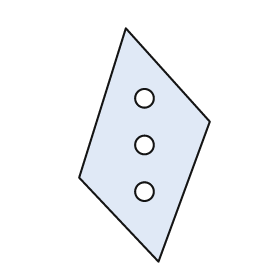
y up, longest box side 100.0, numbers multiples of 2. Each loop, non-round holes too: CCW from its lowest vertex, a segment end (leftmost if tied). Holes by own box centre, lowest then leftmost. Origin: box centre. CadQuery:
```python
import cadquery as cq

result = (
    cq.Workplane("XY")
    .moveTo(6.0, -50.0)
    .lineTo(28.0, 10.0)
    .lineTo(-8.0, 50.0)
    .lineTo(-28.0, -14.0)
    .close()
    .moveTo(0.0, -20.0)
    .circle(4.0)
    .moveTo(0.0, 0.0)
    .circle(4.0)
    .moveTo(0.0, 20.0)
    .circle(4.0)
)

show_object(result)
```